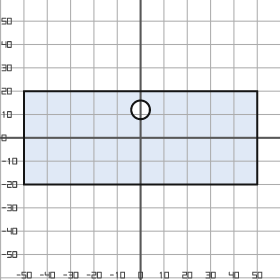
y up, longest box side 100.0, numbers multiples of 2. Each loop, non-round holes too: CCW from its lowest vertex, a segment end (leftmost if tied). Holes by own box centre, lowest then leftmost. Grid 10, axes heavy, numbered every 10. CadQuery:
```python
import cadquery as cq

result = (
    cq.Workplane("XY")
    .moveTo(-50.0, -20.0)
    .lineTo(50.0, -20.0)
    .lineTo(50.0, 20.0)
    .lineTo(-50.0, 20.0)
    .close()
    .moveTo(0.0, 12.0)
    .circle(4.0)
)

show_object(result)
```